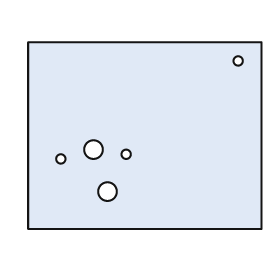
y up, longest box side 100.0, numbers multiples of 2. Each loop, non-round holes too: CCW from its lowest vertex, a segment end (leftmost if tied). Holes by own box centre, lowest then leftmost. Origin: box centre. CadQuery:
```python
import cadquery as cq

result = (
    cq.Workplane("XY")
    .moveTo(-50.0, -40.0)
    .lineTo(50.0, -40.0)
    .lineTo(50.0, 40.0)
    .lineTo(-50.0, 40.0)
    .close()
    .moveTo(-16.0, -24.0)
    .circle(4.0)
    .moveTo(-36.0, -10.0)
    .circle(2.0)
    .moveTo(-8.0, -8.0)
    .circle(2.0)
    .moveTo(-22.0, -6.0)
    .circle(4.0)
    .moveTo(40.0, 32.0)
    .circle(2.0)
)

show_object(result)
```